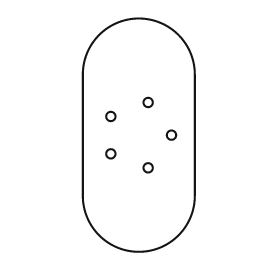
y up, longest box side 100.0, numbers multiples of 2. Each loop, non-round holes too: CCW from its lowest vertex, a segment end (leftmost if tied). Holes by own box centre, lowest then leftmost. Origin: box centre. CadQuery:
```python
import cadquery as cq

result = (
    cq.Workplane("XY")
    .moveTo(-24.0, -26.0)
    .threePointArc((0.0, -50.0), (24.0, -26.0))
    .lineTo(24.0, 26.0)
    .threePointArc((0.0, 50.0), (-24.0, 26.0))
    .close()
    .moveTo(4.0, -14.0)
    .circle(2.0)
    .moveTo(-12.0, -8.0)
    .circle(2.0)
    .moveTo(14.0, 0.0)
    .circle(2.0)
    .moveTo(-12.0, 8.0)
    .circle(2.0)
    .moveTo(4.0, 14.0)
    .circle(2.0)
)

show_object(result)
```